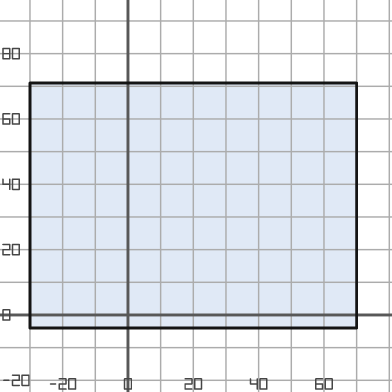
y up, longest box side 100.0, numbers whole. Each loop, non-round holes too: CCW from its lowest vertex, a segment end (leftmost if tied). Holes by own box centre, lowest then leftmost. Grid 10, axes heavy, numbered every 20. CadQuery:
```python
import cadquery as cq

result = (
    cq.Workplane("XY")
    .moveTo(-30.0, -4.0)
    .lineTo(70.0, -4.0)
    .lineTo(70.0, 71.0)
    .lineTo(-30.0, 71.0)
    .close()
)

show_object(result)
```